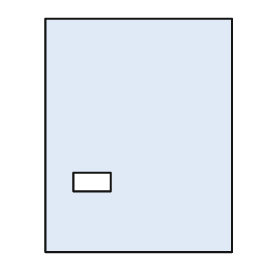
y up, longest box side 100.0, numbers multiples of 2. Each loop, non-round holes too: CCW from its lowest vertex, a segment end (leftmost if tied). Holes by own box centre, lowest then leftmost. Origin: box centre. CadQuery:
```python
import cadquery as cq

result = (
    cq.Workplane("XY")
    .moveTo(-40.0, -50.0)
    .lineTo(40.0, -50.0)
    .lineTo(40.0, 50.0)
    .lineTo(-40.0, 50.0)
    .close()
    .moveTo(-28.0, -24.0)
    .lineTo(-12.0, -24.0)
    .lineTo(-12.0, -16.0)
    .lineTo(-28.0, -16.0)
    .close()
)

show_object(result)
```